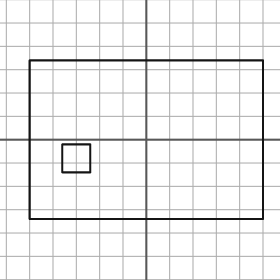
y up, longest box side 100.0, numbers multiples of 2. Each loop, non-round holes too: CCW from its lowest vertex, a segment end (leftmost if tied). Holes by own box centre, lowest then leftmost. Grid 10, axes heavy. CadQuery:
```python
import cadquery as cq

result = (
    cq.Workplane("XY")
    .moveTo(-50.0, -34.0)
    .lineTo(50.0, -34.0)
    .lineTo(50.0, 34.0)
    .lineTo(-50.0, 34.0)
    .close()
    .moveTo(-36.0, -14.0)
    .lineTo(-24.0, -14.0)
    .lineTo(-24.0, -2.0)
    .lineTo(-36.0, -2.0)
    .close()
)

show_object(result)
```